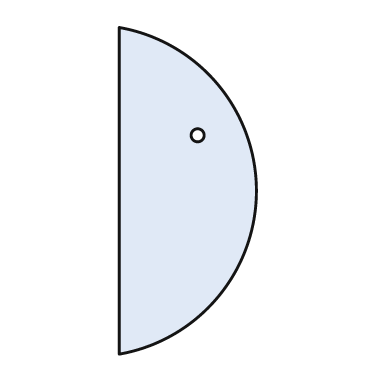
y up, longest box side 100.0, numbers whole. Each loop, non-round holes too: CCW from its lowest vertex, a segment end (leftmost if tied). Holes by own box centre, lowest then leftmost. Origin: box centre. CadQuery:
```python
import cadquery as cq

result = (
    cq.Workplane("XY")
    .moveTo(-21.0, -50.0)
    .threePointArc((21.0, 0.0), (-21.0, 50.0))
    .close()
    .moveTo(3.0, 17.0)
    .circle(2.0)
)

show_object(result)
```